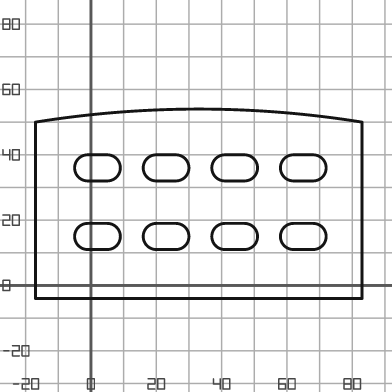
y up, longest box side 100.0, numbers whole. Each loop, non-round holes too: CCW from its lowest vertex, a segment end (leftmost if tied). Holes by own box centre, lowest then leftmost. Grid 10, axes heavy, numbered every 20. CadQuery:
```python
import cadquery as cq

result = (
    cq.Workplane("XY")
    .moveTo(-17.0, -4.0)
    .lineTo(83.0, -4.0)
    .lineTo(83.0, 50.0)
    .threePointArc((33.0, 54.0), (-17.0, 50.0))
    .close()
    .moveTo(-1.0, 11.0)
    .lineTo(5.0, 11.0)
    .threePointArc((9.0, 15.0), (5.0, 19.0))
    .lineTo(-1.0, 19.0)
    .threePointArc((-5.0, 15.0), (-1.0, 11.0))
    .close()
    .moveTo(20.0, 11.0)
    .lineTo(26.0, 11.0)
    .threePointArc((30.0, 15.0), (26.0, 19.0))
    .lineTo(20.0, 19.0)
    .threePointArc((16.0, 15.0), (20.0, 11.0))
    .close()
    .moveTo(41.0, 11.0)
    .lineTo(47.0, 11.0)
    .threePointArc((51.0, 15.0), (47.0, 19.0))
    .lineTo(41.0, 19.0)
    .threePointArc((37.0, 15.0), (41.0, 11.0))
    .close()
    .moveTo(62.0, 11.0)
    .lineTo(68.0, 11.0)
    .threePointArc((72.0, 15.0), (68.0, 19.0))
    .lineTo(62.0, 19.0)
    .threePointArc((58.0, 15.0), (62.0, 11.0))
    .close()
    .moveTo(-1.0, 32.0)
    .lineTo(5.0, 32.0)
    .threePointArc((9.0, 36.0), (5.0, 40.0))
    .lineTo(-1.0, 40.0)
    .threePointArc((-5.0, 36.0), (-1.0, 32.0))
    .close()
    .moveTo(20.0, 32.0)
    .lineTo(26.0, 32.0)
    .threePointArc((30.0, 36.0), (26.0, 40.0))
    .lineTo(20.0, 40.0)
    .threePointArc((16.0, 36.0), (20.0, 32.0))
    .close()
    .moveTo(41.0, 32.0)
    .lineTo(47.0, 32.0)
    .threePointArc((51.0, 36.0), (47.0, 40.0))
    .lineTo(41.0, 40.0)
    .threePointArc((37.0, 36.0), (41.0, 32.0))
    .close()
    .moveTo(62.0, 32.0)
    .lineTo(68.0, 32.0)
    .threePointArc((72.0, 36.0), (68.0, 40.0))
    .lineTo(62.0, 40.0)
    .threePointArc((58.0, 36.0), (62.0, 32.0))
    .close()
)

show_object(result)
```